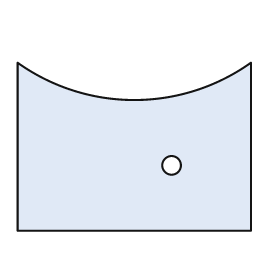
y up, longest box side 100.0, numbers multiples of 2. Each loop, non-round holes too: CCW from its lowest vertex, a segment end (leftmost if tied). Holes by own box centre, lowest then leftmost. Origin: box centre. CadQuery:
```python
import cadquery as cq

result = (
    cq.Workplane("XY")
    .moveTo(-50.0, -36.0)
    .lineTo(50.0, -36.0)
    .lineTo(50.0, 36.0)
    .threePointArc((0.0, 20.0), (-50.0, 36.0))
    .close()
    .moveTo(16.0, -8.0)
    .circle(4.0)
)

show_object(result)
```